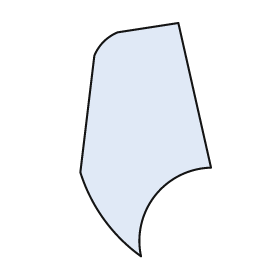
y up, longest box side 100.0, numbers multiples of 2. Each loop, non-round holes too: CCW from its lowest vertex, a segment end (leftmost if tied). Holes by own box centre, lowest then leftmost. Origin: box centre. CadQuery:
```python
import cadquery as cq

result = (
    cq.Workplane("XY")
    .moveTo(-2.0, -50.0)
    .threePointArc((4.0, -24.0), (28.0, -12.0))
    .lineTo(14.0, 50.0)
    .lineTo(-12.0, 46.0)
    .threePointArc((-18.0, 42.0), (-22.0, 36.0))
    .lineTo(-28.0, -14.0)
    .threePointArc((-18.0, -34.0), (-2.0, -50.0))
    .close()
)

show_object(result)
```